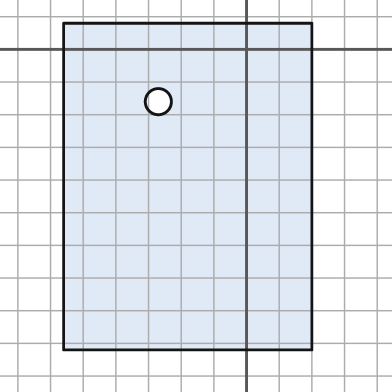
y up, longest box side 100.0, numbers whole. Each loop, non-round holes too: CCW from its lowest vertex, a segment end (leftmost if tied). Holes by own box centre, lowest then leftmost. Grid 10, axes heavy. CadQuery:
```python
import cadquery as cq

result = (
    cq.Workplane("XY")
    .moveTo(-56.0, -92.0)
    .lineTo(20.0, -92.0)
    .lineTo(20.0, 8.0)
    .lineTo(-56.0, 8.0)
    .close()
    .moveTo(-27.0, -16.0)
    .circle(4.0)
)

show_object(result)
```